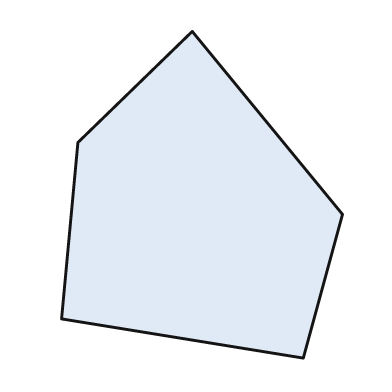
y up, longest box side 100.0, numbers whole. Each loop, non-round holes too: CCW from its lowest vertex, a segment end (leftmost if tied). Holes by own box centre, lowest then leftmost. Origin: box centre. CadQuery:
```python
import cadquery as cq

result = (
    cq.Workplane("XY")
    .moveTo(31.0, -50.0)
    .lineTo(43.0, -6.0)
    .lineTo(-3.0, 50.0)
    .lineTo(-38.0, 16.0)
    .lineTo(-43.0, -38.0)
    .close()
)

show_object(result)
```